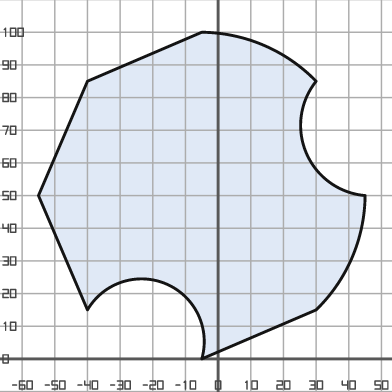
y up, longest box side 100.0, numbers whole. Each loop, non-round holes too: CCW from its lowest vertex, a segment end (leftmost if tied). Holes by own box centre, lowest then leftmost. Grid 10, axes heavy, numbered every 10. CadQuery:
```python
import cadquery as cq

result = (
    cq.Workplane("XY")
    .moveTo(-5.0, 0.0)
    .lineTo(30.0, 15.0)
    .threePointArc((41.0, 31.0), (45.0, 50.0))
    .threePointArc((27.0, 63.0), (30.0, 85.0))
    .threePointArc((14.0, 96.0), (-5.0, 100.0))
    .lineTo(-40.0, 85.0)
    .lineTo(-55.0, 50.0)
    .lineTo(-40.0, 15.0)
    .threePointArc((-16.0, 23.0), (-5.0, 0.0))
    .close()
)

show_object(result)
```